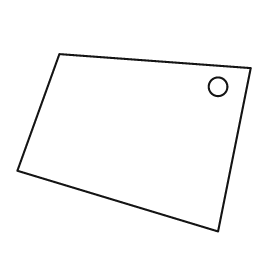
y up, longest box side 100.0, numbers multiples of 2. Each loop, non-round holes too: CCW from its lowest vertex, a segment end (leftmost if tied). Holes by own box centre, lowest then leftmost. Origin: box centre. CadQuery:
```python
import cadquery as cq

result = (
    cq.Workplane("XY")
    .moveTo(36.0, -38.0)
    .lineTo(50.0, 32.0)
    .lineTo(-32.0, 38.0)
    .lineTo(-50.0, -12.0)
    .close()
    .moveTo(36.0, 24.0)
    .circle(4.0)
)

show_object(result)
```